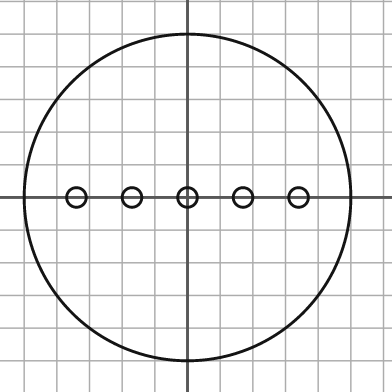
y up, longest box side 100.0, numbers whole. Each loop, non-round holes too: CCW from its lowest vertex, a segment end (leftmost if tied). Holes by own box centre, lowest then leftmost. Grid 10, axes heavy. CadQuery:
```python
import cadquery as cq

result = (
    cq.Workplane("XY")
    .moveTo(0.0, 0.0)
    .circle(50.0)
    .moveTo(-34.0, 0.0)
    .circle(3.0)
    .moveTo(-17.0, 0.0)
    .circle(3.0)
    .moveTo(0.0, 0.0)
    .circle(3.0)
    .moveTo(17.0, 0.0)
    .circle(3.0)
    .moveTo(34.0, 0.0)
    .circle(3.0)
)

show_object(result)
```